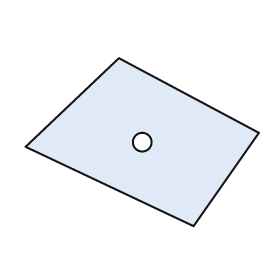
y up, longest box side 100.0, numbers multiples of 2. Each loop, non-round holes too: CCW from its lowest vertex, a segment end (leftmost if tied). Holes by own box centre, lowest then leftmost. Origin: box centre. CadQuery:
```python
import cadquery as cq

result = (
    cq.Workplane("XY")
    .moveTo(22.0, -36.0)
    .lineTo(50.0, 4.0)
    .lineTo(-10.0, 36.0)
    .lineTo(-50.0, -2.0)
    .close()
    .moveTo(0.0, 0.0)
    .circle(4.0)
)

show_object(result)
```